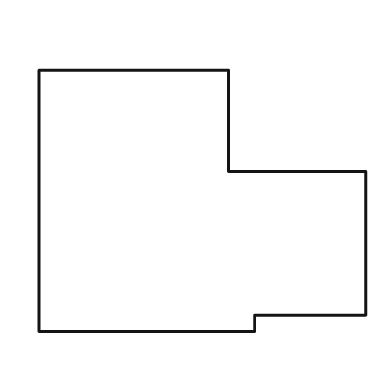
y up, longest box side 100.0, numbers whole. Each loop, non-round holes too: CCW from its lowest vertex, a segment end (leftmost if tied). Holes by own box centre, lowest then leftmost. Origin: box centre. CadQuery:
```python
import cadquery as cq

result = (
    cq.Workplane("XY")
    .moveTo(-50.0, -40.0)
    .lineTo(16.0, -40.0)
    .lineTo(16.0, -35.0)
    .lineTo(50.0, -35.0)
    .lineTo(50.0, 9.0)
    .lineTo(8.0, 9.0)
    .lineTo(8.0, 40.0)
    .lineTo(-50.0, 40.0)
    .close()
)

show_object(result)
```